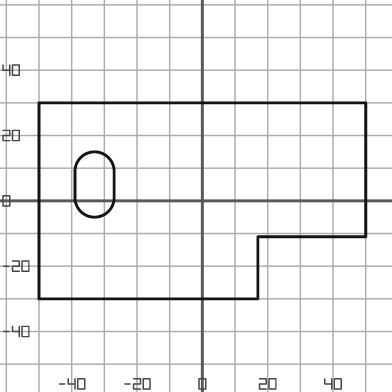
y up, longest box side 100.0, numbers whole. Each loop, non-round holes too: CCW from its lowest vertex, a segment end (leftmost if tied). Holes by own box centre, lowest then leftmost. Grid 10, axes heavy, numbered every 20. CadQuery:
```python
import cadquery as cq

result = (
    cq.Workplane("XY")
    .moveTo(-50.0, -30.0)
    .lineTo(17.0, -30.0)
    .lineTo(17.0, -11.0)
    .lineTo(50.0, -11.0)
    .lineTo(50.0, 30.0)
    .lineTo(-50.0, 30.0)
    .close()
    .moveTo(-39.0, 1.0)
    .threePointArc((-33.0, -5.0), (-27.0, 1.0))
    .lineTo(-27.0, 9.0)
    .threePointArc((-33.0, 15.0), (-39.0, 9.0))
    .close()
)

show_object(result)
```